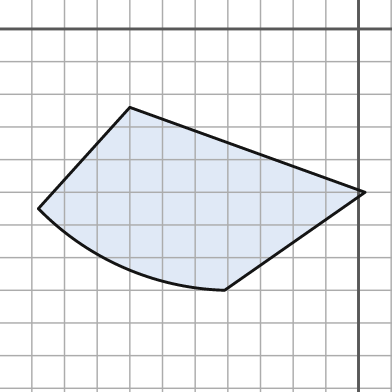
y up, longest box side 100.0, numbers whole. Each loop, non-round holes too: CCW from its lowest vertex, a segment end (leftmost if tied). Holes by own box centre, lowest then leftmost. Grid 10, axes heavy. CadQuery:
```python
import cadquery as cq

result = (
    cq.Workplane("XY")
    .moveTo(-41.0, -80.0)
    .lineTo(2.0, -50.0)
    .lineTo(-70.0, -24.0)
    .lineTo(-98.0, -55.0)
    .threePointArc((-72.0, -73.0), (-41.0, -80.0))
    .close()
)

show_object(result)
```